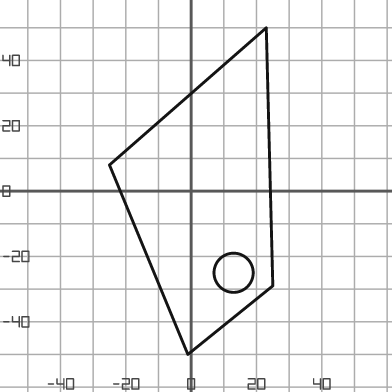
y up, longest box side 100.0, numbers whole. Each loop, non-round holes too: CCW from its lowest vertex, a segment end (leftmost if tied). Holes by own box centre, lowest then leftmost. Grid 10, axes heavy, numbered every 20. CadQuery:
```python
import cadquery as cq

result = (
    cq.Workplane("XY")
    .moveTo(-1.0, -50.0)
    .lineTo(25.0, -29.0)
    .lineTo(23.0, 50.0)
    .lineTo(-25.0, 8.0)
    .close()
    .moveTo(13.0, -25.0)
    .circle(6.0)
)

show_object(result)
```